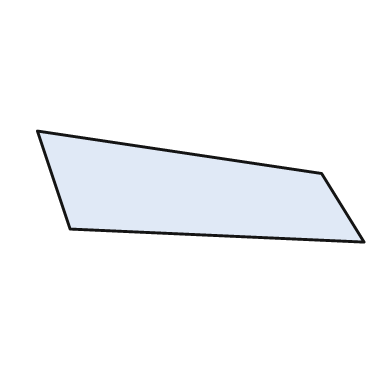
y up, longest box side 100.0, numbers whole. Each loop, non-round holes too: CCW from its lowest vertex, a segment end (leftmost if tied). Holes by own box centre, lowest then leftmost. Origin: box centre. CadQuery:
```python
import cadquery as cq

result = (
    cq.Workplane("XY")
    .moveTo(50.0, -17.0)
    .lineTo(37.0, 4.0)
    .lineTo(-50.0, 17.0)
    .lineTo(-40.0, -13.0)
    .close()
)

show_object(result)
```